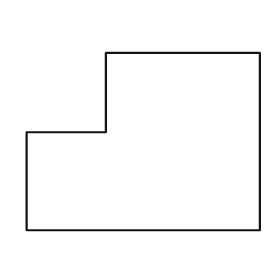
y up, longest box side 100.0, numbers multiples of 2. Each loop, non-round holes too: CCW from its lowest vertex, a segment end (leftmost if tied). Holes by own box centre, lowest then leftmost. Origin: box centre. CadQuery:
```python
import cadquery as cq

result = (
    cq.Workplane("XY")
    .moveTo(-50.0, -38.0)
    .lineTo(50.0, -38.0)
    .lineTo(50.0, 38.0)
    .lineTo(-16.0, 38.0)
    .lineTo(-16.0, 4.0)
    .lineTo(-50.0, 4.0)
    .close()
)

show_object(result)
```